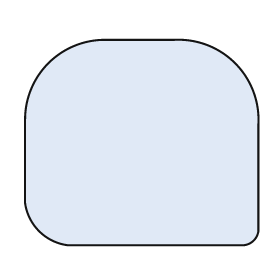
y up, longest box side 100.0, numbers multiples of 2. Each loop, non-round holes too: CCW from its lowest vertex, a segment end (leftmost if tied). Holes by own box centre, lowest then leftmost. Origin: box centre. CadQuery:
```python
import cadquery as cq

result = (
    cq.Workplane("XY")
    .moveTo(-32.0, -44.0)
    .lineTo(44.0, -44.0)
    .threePointArc((48.0, -42.0), (50.0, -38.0))
    .lineTo(50.0, 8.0)
    .threePointArc((40.0, 34.0), (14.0, 44.0))
    .lineTo(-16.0, 44.0)
    .threePointArc((-40.0, 34.0), (-50.0, 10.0))
    .lineTo(-50.0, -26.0)
    .threePointArc((-44.0, -38.0), (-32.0, -44.0))
    .close()
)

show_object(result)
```